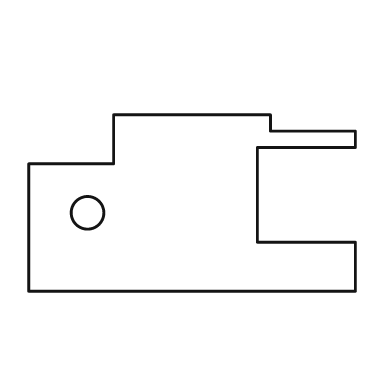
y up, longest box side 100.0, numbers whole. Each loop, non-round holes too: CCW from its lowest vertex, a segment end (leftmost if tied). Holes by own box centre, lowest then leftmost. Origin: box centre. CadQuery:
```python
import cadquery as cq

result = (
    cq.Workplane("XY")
    .moveTo(-50.0, -27.0)
    .lineTo(50.0, -27.0)
    .lineTo(50.0, -12.0)
    .lineTo(20.0, -12.0)
    .lineTo(20.0, 17.0)
    .lineTo(50.0, 17.0)
    .lineTo(50.0, 22.0)
    .lineTo(24.0, 22.0)
    .lineTo(24.0, 27.0)
    .lineTo(-24.0, 27.0)
    .lineTo(-24.0, 12.0)
    .lineTo(-50.0, 12.0)
    .close()
    .moveTo(-32.0, -3.0)
    .circle(5.0)
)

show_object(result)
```